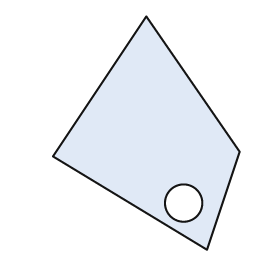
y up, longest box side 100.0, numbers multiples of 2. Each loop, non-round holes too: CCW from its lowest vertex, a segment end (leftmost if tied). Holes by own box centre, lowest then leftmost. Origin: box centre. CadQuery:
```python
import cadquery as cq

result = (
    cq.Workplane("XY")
    .moveTo(26.0, -50.0)
    .lineTo(40.0, -8.0)
    .lineTo(0.0, 50.0)
    .lineTo(-40.0, -10.0)
    .close()
    .moveTo(16.0, -30.0)
    .circle(8.0)
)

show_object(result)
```